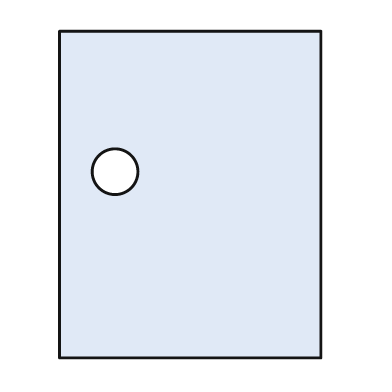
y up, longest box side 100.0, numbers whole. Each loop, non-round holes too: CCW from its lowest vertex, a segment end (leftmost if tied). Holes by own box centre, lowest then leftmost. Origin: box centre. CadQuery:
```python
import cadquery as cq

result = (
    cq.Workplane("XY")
    .moveTo(-40.0, -50.0)
    .lineTo(40.0, -50.0)
    .lineTo(40.0, 50.0)
    .lineTo(-40.0, 50.0)
    .close()
    .moveTo(-23.0, 7.0)
    .circle(7.0)
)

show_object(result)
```